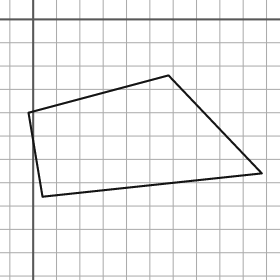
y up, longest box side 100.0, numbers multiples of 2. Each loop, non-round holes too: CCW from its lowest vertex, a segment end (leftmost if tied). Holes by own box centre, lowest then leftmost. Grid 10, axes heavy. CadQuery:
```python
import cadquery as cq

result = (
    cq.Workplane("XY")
    .moveTo(4.0, -76.0)
    .lineTo(98.0, -66.0)
    .lineTo(58.0, -24.0)
    .lineTo(-2.0, -40.0)
    .close()
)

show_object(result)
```